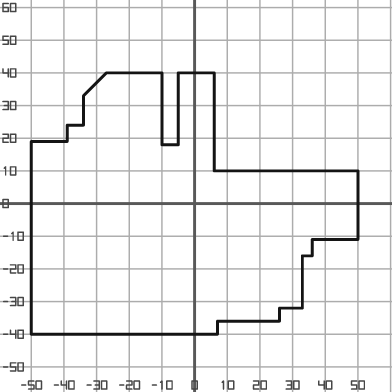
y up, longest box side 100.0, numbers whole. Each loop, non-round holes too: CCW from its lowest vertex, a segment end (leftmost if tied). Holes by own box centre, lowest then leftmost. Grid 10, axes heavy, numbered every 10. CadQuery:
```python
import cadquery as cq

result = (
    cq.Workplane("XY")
    .moveTo(-50.0, -40.0)
    .lineTo(7.0, -40.0)
    .lineTo(7.0, -36.0)
    .lineTo(26.0, -36.0)
    .lineTo(26.0, -32.0)
    .lineTo(33.0, -32.0)
    .lineTo(33.0, -16.0)
    .lineTo(36.0, -16.0)
    .lineTo(36.0, -11.0)
    .lineTo(50.0, -11.0)
    .lineTo(50.0, 10.0)
    .lineTo(6.0, 10.0)
    .lineTo(6.0, 40.0)
    .lineTo(-5.0, 40.0)
    .lineTo(-5.0, 18.0)
    .lineTo(-10.0, 18.0)
    .lineTo(-10.0, 40.0)
    .lineTo(-27.0, 40.0)
    .lineTo(-34.0, 33.0)
    .lineTo(-34.0, 24.0)
    .lineTo(-39.0, 24.0)
    .lineTo(-39.0, 19.0)
    .lineTo(-50.0, 19.0)
    .close()
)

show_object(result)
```